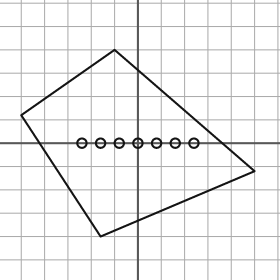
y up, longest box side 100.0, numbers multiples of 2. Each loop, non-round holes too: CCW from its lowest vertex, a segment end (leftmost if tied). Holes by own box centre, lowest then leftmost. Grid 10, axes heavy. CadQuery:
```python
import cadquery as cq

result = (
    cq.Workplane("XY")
    .moveTo(-16.0, -40.0)
    .lineTo(50.0, -12.0)
    .lineTo(-10.0, 40.0)
    .lineTo(-50.0, 12.0)
    .close()
    .moveTo(-24.0, 0.0)
    .circle(2.0)
    .moveTo(-16.0, 0.0)
    .circle(2.0)
    .moveTo(-8.0, 0.0)
    .circle(2.0)
    .moveTo(0.0, 0.0)
    .circle(2.0)
    .moveTo(8.0, 0.0)
    .circle(2.0)
    .moveTo(16.0, 0.0)
    .circle(2.0)
    .moveTo(24.0, 0.0)
    .circle(2.0)
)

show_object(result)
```